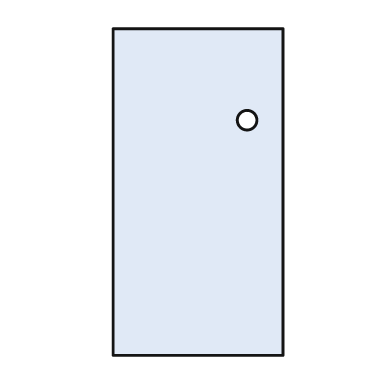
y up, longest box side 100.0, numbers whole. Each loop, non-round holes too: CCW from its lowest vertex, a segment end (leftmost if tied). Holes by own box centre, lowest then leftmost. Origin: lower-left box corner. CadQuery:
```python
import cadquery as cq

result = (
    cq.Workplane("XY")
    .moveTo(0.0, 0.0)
    .lineTo(52.0, 0.0)
    .lineTo(52.0, 100.0)
    .lineTo(0.0, 100.0)
    .close()
    .moveTo(41.0, 72.0)
    .circle(3.0)
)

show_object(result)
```